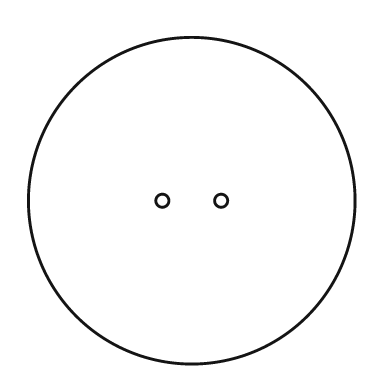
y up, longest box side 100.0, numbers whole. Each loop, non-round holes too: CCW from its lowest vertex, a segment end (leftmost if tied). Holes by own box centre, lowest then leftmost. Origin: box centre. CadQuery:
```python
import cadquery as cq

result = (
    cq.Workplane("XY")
    .moveTo(0.0, 0.0)
    .circle(50.0)
    .moveTo(-9.0, 0.0)
    .circle(2.0)
    .moveTo(9.0, 0.0)
    .circle(2.0)
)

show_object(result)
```